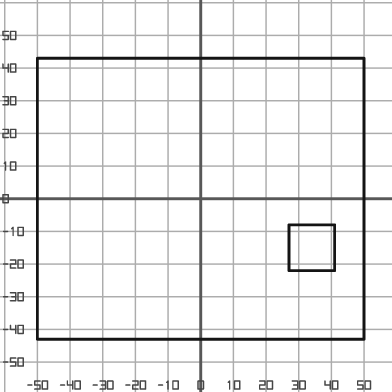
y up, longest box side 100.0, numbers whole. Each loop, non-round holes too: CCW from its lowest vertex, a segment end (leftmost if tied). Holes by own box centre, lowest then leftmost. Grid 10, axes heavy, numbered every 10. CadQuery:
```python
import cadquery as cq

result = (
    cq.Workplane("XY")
    .moveTo(-50.0, -43.0)
    .lineTo(50.0, -43.0)
    .lineTo(50.0, 43.0)
    .lineTo(-50.0, 43.0)
    .close()
    .moveTo(27.0, -22.0)
    .lineTo(41.0, -22.0)
    .lineTo(41.0, -8.0)
    .lineTo(27.0, -8.0)
    .close()
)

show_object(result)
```